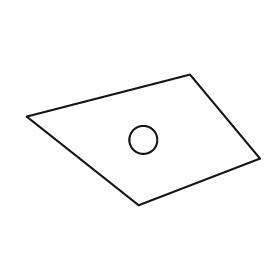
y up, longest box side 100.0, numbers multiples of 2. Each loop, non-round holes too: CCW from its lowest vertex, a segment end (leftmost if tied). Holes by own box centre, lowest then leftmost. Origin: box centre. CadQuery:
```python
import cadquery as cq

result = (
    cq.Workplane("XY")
    .moveTo(-2.0, -28.0)
    .lineTo(50.0, -8.0)
    .lineTo(20.0, 28.0)
    .lineTo(-50.0, 10.0)
    .close()
    .moveTo(0.0, 0.0)
    .circle(6.0)
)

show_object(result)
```